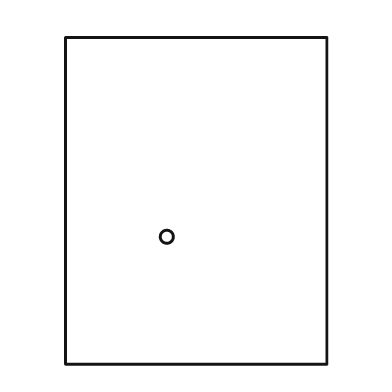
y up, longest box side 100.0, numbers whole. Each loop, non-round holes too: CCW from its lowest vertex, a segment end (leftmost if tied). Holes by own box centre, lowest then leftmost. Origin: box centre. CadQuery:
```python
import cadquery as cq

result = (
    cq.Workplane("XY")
    .moveTo(-40.0, -50.0)
    .lineTo(40.0, -50.0)
    .lineTo(40.0, 50.0)
    .lineTo(-40.0, 50.0)
    .close()
    .moveTo(-9.0, -11.0)
    .circle(2.0)
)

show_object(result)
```